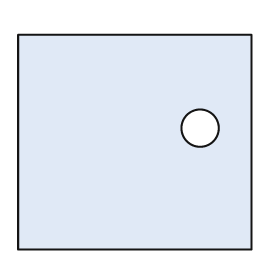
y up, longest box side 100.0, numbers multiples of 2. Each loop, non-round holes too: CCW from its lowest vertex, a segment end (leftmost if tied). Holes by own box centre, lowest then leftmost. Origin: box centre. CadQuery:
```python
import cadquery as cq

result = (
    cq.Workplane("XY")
    .moveTo(-50.0, -46.0)
    .lineTo(50.0, -46.0)
    .lineTo(50.0, 46.0)
    .lineTo(-50.0, 46.0)
    .close()
    .moveTo(28.0, 6.0)
    .circle(8.0)
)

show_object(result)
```